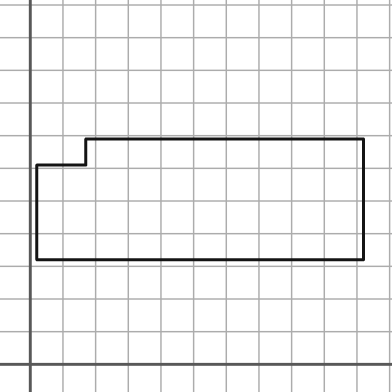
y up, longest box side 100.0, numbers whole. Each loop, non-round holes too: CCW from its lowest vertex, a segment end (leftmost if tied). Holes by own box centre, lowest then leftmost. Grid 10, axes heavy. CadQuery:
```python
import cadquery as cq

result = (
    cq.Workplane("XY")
    .moveTo(2.0, 32.0)
    .lineTo(102.0, 32.0)
    .lineTo(102.0, 69.0)
    .lineTo(17.0, 69.0)
    .lineTo(17.0, 61.0)
    .lineTo(2.0, 61.0)
    .close()
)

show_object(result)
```